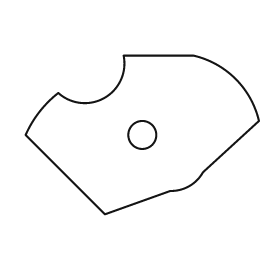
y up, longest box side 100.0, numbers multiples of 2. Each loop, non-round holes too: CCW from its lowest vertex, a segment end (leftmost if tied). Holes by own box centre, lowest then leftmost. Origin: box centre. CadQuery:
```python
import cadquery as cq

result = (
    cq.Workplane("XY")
    .moveTo(-16.0, -34.0)
    .lineTo(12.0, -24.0)
    .threePointArc((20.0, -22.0), (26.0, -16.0))
    .lineTo(50.0, 6.0)
    .threePointArc((40.0, 24.0), (22.0, 34.0))
    .lineTo(-8.0, 34.0)
    .threePointArc((-16.0, 16.0), (-36.0, 18.0))
    .threePointArc((-44.0, 10.0), (-50.0, 0.0))
    .close()
    .moveTo(0.0, 0.0)
    .circle(6.0)
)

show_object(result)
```